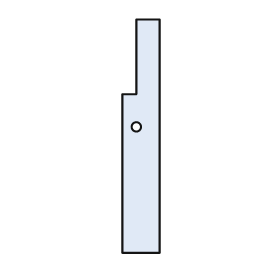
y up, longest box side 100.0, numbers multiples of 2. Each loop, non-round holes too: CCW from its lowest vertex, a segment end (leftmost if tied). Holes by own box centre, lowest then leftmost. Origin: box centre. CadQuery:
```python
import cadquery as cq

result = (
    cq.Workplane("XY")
    .moveTo(-8.0, -50.0)
    .lineTo(8.0, -50.0)
    .lineTo(8.0, 50.0)
    .lineTo(-2.0, 50.0)
    .lineTo(-2.0, 18.0)
    .lineTo(-8.0, 18.0)
    .close()
    .moveTo(-2.0, 4.0)
    .circle(2.0)
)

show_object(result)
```